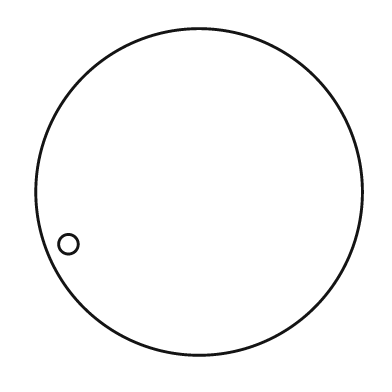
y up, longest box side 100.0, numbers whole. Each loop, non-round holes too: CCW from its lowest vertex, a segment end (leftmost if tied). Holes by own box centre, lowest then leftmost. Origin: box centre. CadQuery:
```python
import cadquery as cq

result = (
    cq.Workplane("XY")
    .moveTo(0.0, 0.0)
    .circle(50.0)
    .moveTo(-40.0, -16.0)
    .circle(3.0)
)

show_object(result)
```